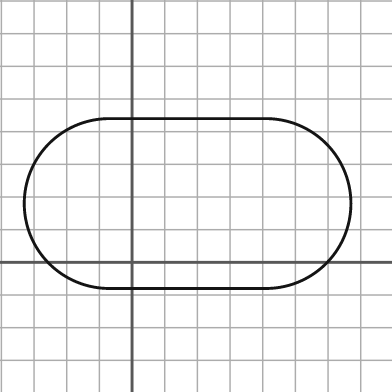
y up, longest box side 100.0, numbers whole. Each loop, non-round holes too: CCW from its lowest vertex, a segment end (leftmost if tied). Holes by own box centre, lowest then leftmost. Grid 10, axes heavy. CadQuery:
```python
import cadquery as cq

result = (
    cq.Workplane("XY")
    .moveTo(-7.0, -8.0)
    .lineTo(41.0, -8.0)
    .threePointArc((67.0, 18.0), (41.0, 44.0))
    .lineTo(-7.0, 44.0)
    .threePointArc((-33.0, 18.0), (-7.0, -8.0))
    .close()
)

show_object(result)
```